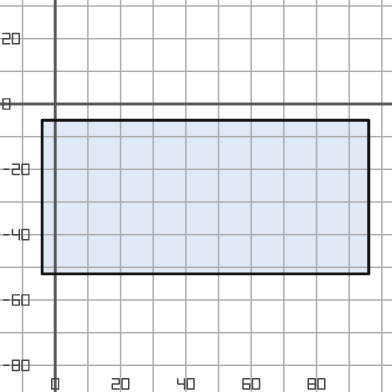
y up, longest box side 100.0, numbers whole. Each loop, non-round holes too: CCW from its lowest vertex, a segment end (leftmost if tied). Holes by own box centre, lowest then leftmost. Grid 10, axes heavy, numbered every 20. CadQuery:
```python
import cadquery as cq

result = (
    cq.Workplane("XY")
    .moveTo(-4.0, -52.0)
    .lineTo(96.0, -52.0)
    .lineTo(96.0, -5.0)
    .lineTo(-4.0, -5.0)
    .close()
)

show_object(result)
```